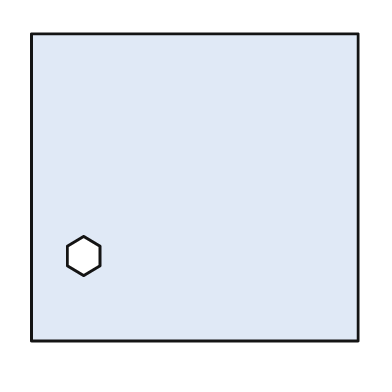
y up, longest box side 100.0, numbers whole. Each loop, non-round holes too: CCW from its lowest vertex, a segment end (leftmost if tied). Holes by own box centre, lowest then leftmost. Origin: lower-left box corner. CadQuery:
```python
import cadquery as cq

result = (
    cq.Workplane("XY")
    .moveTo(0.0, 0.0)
    .lineTo(100.0, 0.0)
    .lineTo(100.0, 94.0)
    .lineTo(0.0, 94.0)
    .close()
    .moveTo(16.0, 20.0)
    .lineTo(21.0, 23.0)
    .lineTo(21.0, 29.0)
    .lineTo(16.0, 32.0)
    .lineTo(11.0, 29.0)
    .lineTo(11.0, 23.0)
    .close()
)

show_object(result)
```